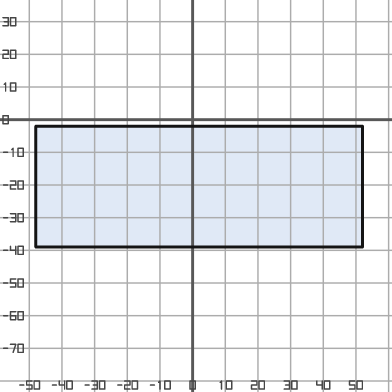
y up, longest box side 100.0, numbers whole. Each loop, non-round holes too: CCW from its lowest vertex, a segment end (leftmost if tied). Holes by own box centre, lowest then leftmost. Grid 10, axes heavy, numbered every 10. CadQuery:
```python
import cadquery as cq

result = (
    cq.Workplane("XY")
    .moveTo(-48.0, -39.0)
    .lineTo(52.0, -39.0)
    .lineTo(52.0, -2.0)
    .lineTo(-48.0, -2.0)
    .close()
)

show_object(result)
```